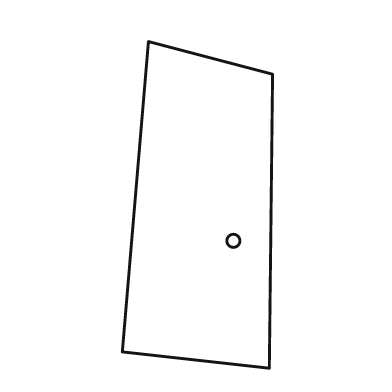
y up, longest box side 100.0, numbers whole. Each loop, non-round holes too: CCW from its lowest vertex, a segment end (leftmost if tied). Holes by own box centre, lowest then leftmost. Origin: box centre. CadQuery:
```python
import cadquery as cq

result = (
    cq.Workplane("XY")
    .moveTo(22.0, -50.0)
    .lineTo(23.0, 40.0)
    .lineTo(-15.0, 50.0)
    .lineTo(-23.0, -45.0)
    .close()
    .moveTo(11.0, -11.0)
    .circle(2.0)
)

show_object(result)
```